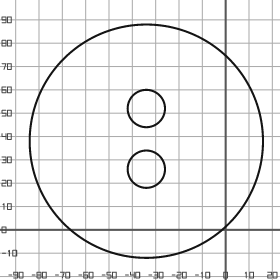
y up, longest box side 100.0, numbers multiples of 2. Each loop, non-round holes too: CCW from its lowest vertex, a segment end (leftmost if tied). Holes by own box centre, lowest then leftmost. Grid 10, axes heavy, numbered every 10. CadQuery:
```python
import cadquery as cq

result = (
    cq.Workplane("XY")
    .moveTo(-34.0, 38.0)
    .circle(50.0)
    .moveTo(-34.0, 26.0)
    .circle(8.0)
    .moveTo(-34.0, 52.0)
    .circle(8.0)
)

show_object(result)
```